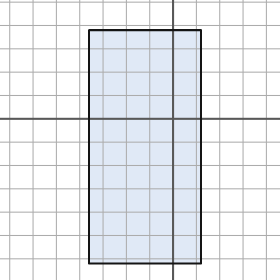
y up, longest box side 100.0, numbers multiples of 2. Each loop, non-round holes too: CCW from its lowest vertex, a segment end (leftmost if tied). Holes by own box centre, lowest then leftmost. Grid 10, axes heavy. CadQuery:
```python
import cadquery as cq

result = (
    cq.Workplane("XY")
    .moveTo(-36.0, -62.0)
    .lineTo(12.0, -62.0)
    .lineTo(12.0, 38.0)
    .lineTo(-36.0, 38.0)
    .close()
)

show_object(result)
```